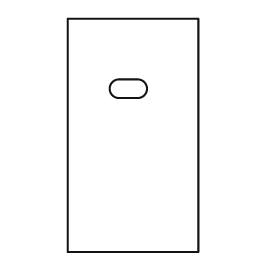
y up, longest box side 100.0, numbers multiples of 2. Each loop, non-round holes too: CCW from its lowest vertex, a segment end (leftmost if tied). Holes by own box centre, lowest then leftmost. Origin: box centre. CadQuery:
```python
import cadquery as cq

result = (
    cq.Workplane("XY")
    .moveTo(-28.0, -50.0)
    .lineTo(28.0, -50.0)
    .lineTo(28.0, 50.0)
    .lineTo(-28.0, 50.0)
    .close()
    .moveTo(-6.0, 16.0)
    .lineTo(2.0, 16.0)
    .threePointArc((6.0, 20.0), (2.0, 24.0))
    .lineTo(-6.0, 24.0)
    .threePointArc((-10.0, 20.0), (-6.0, 16.0))
    .close()
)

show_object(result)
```